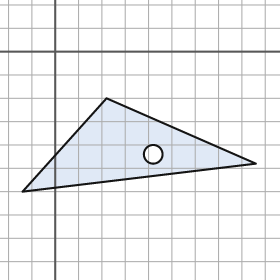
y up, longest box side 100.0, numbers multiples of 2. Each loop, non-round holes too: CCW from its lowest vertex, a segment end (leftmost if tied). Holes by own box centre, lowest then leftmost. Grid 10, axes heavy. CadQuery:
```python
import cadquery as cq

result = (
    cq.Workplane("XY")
    .moveTo(-14.0, -60.0)
    .lineTo(86.0, -48.0)
    .lineTo(22.0, -20.0)
    .close()
    .moveTo(42.0, -44.0)
    .circle(4.0)
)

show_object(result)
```